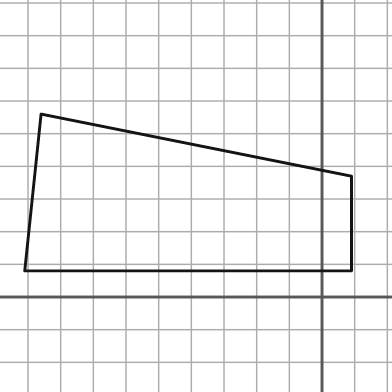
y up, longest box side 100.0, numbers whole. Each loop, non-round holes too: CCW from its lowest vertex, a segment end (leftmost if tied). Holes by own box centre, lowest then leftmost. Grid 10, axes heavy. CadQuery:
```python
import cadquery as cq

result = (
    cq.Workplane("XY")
    .moveTo(-91.0, 8.0)
    .lineTo(9.0, 8.0)
    .lineTo(9.0, 37.0)
    .lineTo(-86.0, 56.0)
    .close()
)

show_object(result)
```